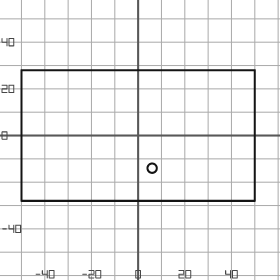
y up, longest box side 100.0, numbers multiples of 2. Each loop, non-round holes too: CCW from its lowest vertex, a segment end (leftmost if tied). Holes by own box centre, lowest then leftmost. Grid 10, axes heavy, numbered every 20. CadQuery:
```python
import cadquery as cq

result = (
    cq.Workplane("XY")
    .moveTo(-50.0, -28.0)
    .lineTo(50.0, -28.0)
    .lineTo(50.0, 28.0)
    .lineTo(-50.0, 28.0)
    .close()
    .moveTo(6.0, -14.0)
    .circle(2.0)
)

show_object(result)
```